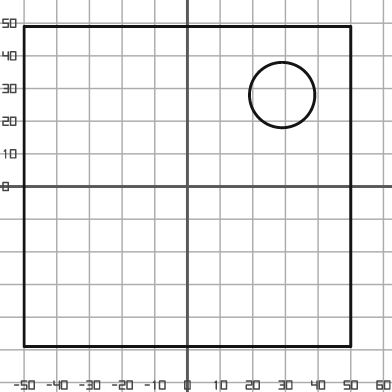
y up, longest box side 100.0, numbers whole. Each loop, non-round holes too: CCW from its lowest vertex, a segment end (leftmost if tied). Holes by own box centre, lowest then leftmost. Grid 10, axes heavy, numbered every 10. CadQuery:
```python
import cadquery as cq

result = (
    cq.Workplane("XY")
    .moveTo(-50.0, -49.0)
    .lineTo(50.0, -49.0)
    .lineTo(50.0, 49.0)
    .lineTo(-50.0, 49.0)
    .close()
    .moveTo(29.0, 28.0)
    .circle(10.0)
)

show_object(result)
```